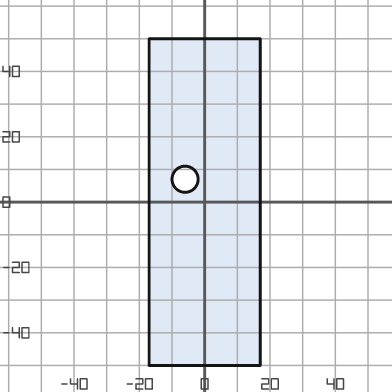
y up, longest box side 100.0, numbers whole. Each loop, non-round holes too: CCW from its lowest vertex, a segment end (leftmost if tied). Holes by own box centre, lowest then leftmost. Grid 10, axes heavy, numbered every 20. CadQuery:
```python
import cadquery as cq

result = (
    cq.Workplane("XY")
    .moveTo(-17.0, -50.0)
    .lineTo(17.0, -50.0)
    .lineTo(17.0, 50.0)
    .lineTo(-17.0, 50.0)
    .close()
    .moveTo(-6.0, 7.0)
    .circle(4.0)
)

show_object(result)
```